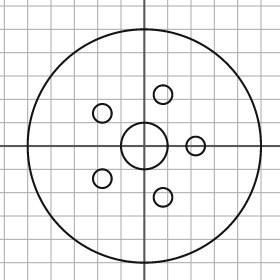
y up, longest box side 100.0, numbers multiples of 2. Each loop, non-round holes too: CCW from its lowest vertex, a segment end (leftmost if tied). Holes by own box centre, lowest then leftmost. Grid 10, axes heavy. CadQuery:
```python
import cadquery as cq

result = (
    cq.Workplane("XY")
    .moveTo(0.0, 0.0)
    .circle(50.0)
    .moveTo(8.0, -22.0)
    .circle(4.0)
    .moveTo(-18.0, -14.0)
    .circle(4.0)
    .moveTo(0.0, 0.0)
    .circle(10.0)
    .moveTo(22.0, 0.0)
    .circle(4.0)
    .moveTo(-18.0, 14.0)
    .circle(4.0)
    .moveTo(8.0, 22.0)
    .circle(4.0)
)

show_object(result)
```